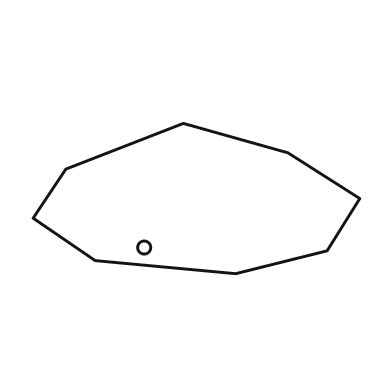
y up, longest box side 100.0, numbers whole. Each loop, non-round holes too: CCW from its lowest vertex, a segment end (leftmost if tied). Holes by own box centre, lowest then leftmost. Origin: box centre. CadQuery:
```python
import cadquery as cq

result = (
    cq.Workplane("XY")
    .moveTo(12.0, -23.0)
    .lineTo(40.0, -16.0)
    .lineTo(50.0, 0.0)
    .lineTo(28.0, 14.0)
    .lineTo(-4.0, 23.0)
    .lineTo(-40.0, 9.0)
    .lineTo(-50.0, -6.0)
    .lineTo(-31.0, -19.0)
    .close()
    .moveTo(-16.0, -15.0)
    .circle(2.0)
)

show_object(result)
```